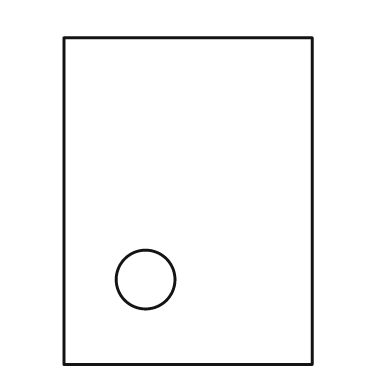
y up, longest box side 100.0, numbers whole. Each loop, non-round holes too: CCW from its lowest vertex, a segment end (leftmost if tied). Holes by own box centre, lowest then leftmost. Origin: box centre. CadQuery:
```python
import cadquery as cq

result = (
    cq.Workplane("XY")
    .moveTo(-38.0, -50.0)
    .lineTo(38.0, -50.0)
    .lineTo(38.0, 50.0)
    .lineTo(-38.0, 50.0)
    .close()
    .moveTo(-13.0, -24.0)
    .circle(9.0)
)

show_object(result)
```